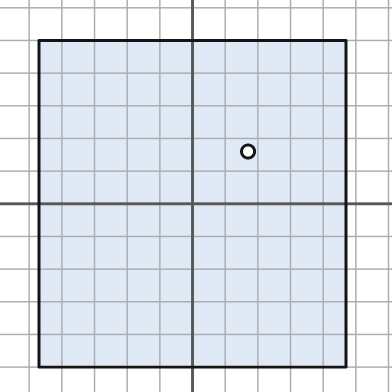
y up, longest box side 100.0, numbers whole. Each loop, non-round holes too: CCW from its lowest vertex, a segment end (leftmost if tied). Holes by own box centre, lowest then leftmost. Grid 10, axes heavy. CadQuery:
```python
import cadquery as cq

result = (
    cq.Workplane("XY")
    .moveTo(-47.0, -50.0)
    .lineTo(47.0, -50.0)
    .lineTo(47.0, 50.0)
    .lineTo(-47.0, 50.0)
    .close()
    .moveTo(17.0, 16.0)
    .circle(2.0)
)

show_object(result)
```